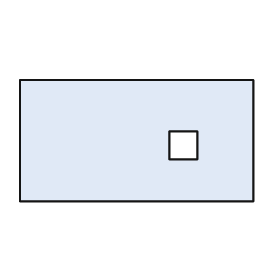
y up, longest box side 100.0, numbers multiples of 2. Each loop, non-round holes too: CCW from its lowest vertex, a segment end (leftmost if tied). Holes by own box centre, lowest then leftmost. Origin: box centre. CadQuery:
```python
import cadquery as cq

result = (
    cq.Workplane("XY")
    .moveTo(-50.0, -26.0)
    .lineTo(50.0, -26.0)
    .lineTo(50.0, 26.0)
    .lineTo(-50.0, 26.0)
    .close()
    .moveTo(14.0, -8.0)
    .lineTo(26.0, -8.0)
    .lineTo(26.0, 4.0)
    .lineTo(14.0, 4.0)
    .close()
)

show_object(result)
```